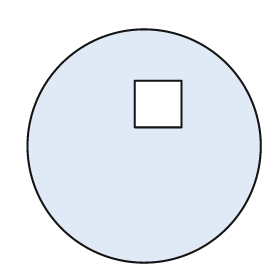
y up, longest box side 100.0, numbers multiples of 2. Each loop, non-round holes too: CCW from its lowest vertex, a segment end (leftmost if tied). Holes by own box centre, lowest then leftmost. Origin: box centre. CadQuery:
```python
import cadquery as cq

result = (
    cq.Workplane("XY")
    .moveTo(0.0, 0.0)
    .circle(50.0)
    .moveTo(-4.0, 8.0)
    .lineTo(16.0, 8.0)
    .lineTo(16.0, 28.0)
    .lineTo(-4.0, 28.0)
    .close()
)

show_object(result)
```